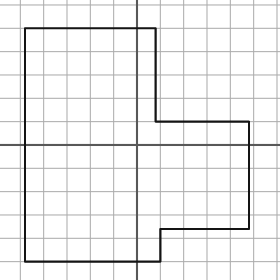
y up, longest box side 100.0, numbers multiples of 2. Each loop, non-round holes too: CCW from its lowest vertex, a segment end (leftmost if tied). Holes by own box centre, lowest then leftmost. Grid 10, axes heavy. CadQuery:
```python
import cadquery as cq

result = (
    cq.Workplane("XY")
    .moveTo(-48.0, -50.0)
    .lineTo(10.0, -50.0)
    .lineTo(10.0, -36.0)
    .lineTo(48.0, -36.0)
    .lineTo(48.0, 10.0)
    .lineTo(8.0, 10.0)
    .lineTo(8.0, 50.0)
    .lineTo(-48.0, 50.0)
    .close()
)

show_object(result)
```